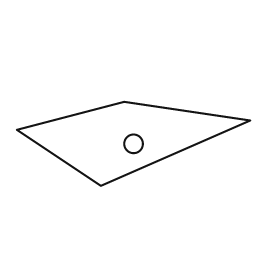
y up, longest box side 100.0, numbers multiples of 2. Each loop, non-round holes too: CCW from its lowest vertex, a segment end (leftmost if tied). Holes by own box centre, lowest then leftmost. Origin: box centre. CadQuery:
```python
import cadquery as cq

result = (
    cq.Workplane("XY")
    .moveTo(-14.0, -18.0)
    .lineTo(50.0, 10.0)
    .lineTo(-4.0, 18.0)
    .lineTo(-50.0, 6.0)
    .close()
    .moveTo(0.0, 0.0)
    .circle(4.0)
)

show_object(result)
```